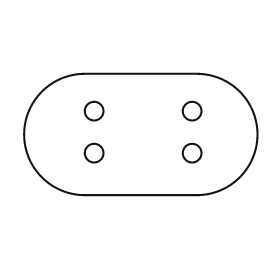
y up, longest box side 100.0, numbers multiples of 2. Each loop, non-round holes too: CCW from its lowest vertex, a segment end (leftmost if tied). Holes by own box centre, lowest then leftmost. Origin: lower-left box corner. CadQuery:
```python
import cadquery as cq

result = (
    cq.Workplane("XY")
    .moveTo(26.0, 0.0)
    .lineTo(74.0, 0.0)
    .threePointArc((100.0, 26.0), (74.0, 52.0))
    .lineTo(26.0, 52.0)
    .threePointArc((0.0, 26.0), (26.0, 0.0))
    .close()
    .moveTo(30.0, 18.0)
    .circle(4.0)
    .moveTo(72.0, 18.0)
    .circle(4.0)
    .moveTo(30.0, 36.0)
    .circle(4.0)
    .moveTo(72.0, 36.0)
    .circle(4.0)
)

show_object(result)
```